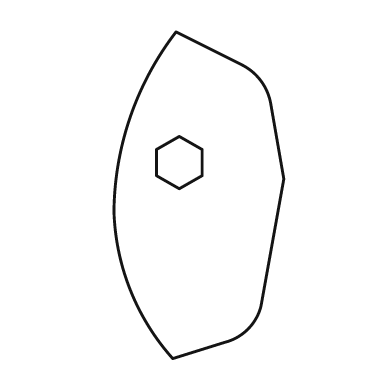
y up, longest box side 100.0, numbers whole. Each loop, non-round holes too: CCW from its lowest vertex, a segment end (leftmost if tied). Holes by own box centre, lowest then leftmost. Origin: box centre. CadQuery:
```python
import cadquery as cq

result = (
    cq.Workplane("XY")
    .moveTo(-8.0, -50.0)
    .lineTo(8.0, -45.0)
    .threePointArc((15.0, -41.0), (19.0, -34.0))
    .lineTo(26.0, 5.0)
    .lineTo(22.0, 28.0)
    .threePointArc((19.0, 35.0), (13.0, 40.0))
    .lineTo(-7.0, 50.0)
    .threePointArc((-21.0, 24.0), (-26.0, -5.0))
    .threePointArc((-21.0, -29.0), (-8.0, -50.0))
    .close()
    .moveTo(-6.0, 2.0)
    .lineTo(1.0, 6.0)
    .lineTo(1.0, 14.0)
    .lineTo(-6.0, 18.0)
    .lineTo(-13.0, 14.0)
    .lineTo(-13.0, 6.0)
    .close()
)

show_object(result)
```